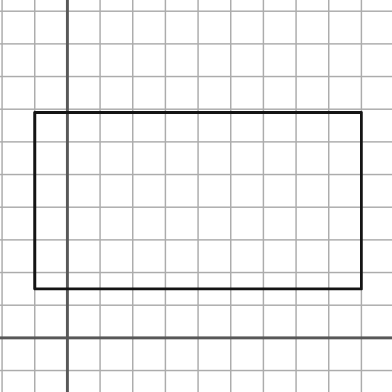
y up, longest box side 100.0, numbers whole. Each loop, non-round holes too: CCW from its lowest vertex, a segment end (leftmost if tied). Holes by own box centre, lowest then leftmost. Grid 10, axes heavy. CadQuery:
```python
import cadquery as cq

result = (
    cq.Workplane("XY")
    .moveTo(-10.0, 15.0)
    .lineTo(90.0, 15.0)
    .lineTo(90.0, 69.0)
    .lineTo(-10.0, 69.0)
    .close()
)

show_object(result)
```